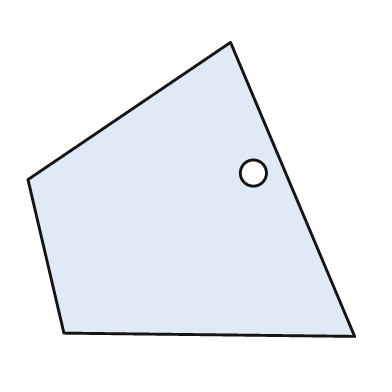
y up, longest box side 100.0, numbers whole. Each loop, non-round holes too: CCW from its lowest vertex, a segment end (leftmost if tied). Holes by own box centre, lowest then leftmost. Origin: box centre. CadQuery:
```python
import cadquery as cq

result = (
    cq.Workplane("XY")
    .moveTo(50.0, -45.0)
    .lineTo(12.0, 45.0)
    .lineTo(-50.0, 3.0)
    .lineTo(-39.0, -44.0)
    .close()
    .moveTo(19.0, 5.0)
    .circle(4.0)
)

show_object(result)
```